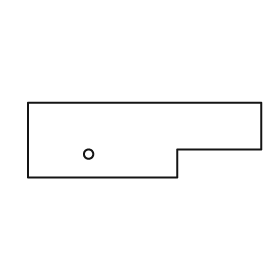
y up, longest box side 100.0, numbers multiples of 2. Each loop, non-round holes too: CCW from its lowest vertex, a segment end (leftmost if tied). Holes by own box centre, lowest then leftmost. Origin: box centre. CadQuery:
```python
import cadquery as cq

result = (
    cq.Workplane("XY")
    .moveTo(-50.0, -16.0)
    .lineTo(14.0, -16.0)
    .lineTo(14.0, -4.0)
    .lineTo(50.0, -4.0)
    .lineTo(50.0, 16.0)
    .lineTo(-50.0, 16.0)
    .close()
    .moveTo(-24.0, -6.0)
    .circle(2.0)
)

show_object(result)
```